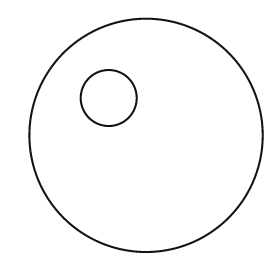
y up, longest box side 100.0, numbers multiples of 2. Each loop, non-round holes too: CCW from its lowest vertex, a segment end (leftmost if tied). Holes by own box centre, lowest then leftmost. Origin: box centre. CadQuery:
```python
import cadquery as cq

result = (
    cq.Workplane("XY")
    .moveTo(0.0, 0.0)
    .circle(50.0)
    .moveTo(-16.0, 16.0)
    .circle(12.0)
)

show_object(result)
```